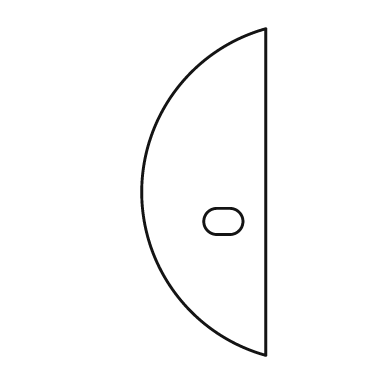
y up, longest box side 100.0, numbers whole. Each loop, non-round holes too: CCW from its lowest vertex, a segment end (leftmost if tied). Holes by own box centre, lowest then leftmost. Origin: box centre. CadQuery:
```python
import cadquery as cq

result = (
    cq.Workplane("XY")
    .moveTo(19.0, -50.0)
    .lineTo(19.0, 50.0)
    .threePointArc((-19.0, 0.0), (19.0, -50.0))
    .close()
    .moveTo(4.0, -13.0)
    .lineTo(8.0, -13.0)
    .threePointArc((12.0, -9.0), (8.0, -5.0))
    .lineTo(4.0, -5.0)
    .threePointArc((0.0, -9.0), (4.0, -13.0))
    .close()
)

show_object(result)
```